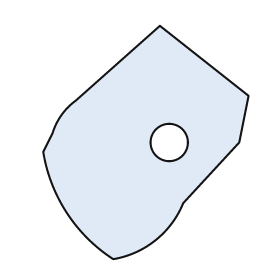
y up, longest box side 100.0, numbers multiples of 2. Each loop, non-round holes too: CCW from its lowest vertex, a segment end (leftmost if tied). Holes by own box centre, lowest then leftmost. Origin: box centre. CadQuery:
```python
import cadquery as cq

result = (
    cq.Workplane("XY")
    .moveTo(-14.0, -50.0)
    .threePointArc((4.0, -42.0), (16.0, -26.0))
    .lineTo(40.0, 0.0)
    .lineTo(44.0, 20.0)
    .lineTo(6.0, 50.0)
    .lineTo(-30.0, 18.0)
    .threePointArc((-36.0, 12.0), (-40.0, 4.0))
    .lineTo(-44.0, -4.0)
    .threePointArc((-34.0, -30.0), (-14.0, -50.0))
    .close()
    .moveTo(10.0, 0.0)
    .circle(8.0)
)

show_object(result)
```